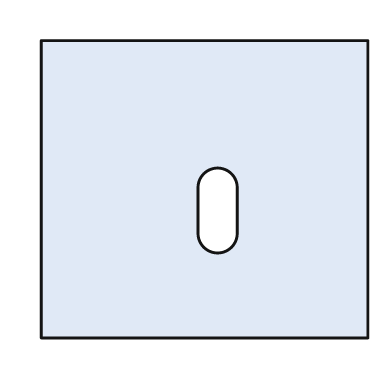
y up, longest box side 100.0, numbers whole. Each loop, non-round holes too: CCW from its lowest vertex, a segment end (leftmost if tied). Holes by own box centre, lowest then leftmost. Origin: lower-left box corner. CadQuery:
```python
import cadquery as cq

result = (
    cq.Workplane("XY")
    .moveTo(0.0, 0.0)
    .lineTo(100.0, 0.0)
    .lineTo(100.0, 91.0)
    .lineTo(0.0, 91.0)
    .close()
    .moveTo(48.0, 32.0)
    .threePointArc((54.0, 26.0), (60.0, 32.0))
    .lineTo(60.0, 46.0)
    .threePointArc((54.0, 52.0), (48.0, 46.0))
    .close()
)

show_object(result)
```